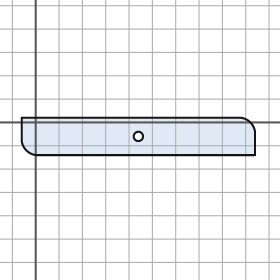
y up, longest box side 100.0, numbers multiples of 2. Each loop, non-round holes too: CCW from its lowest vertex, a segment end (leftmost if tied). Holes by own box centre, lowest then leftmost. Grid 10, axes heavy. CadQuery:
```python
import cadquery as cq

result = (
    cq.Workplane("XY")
    .moveTo(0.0, -14.0)
    .lineTo(94.0, -14.0)
    .lineTo(94.0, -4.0)
    .threePointArc((92.0, 0.0), (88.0, 2.0))
    .lineTo(-6.0, 2.0)
    .lineTo(-6.0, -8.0)
    .threePointArc((-4.0, -12.0), (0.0, -14.0))
    .close()
    .moveTo(44.0, -6.0)
    .circle(2.0)
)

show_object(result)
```